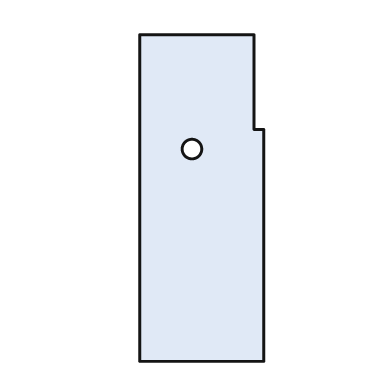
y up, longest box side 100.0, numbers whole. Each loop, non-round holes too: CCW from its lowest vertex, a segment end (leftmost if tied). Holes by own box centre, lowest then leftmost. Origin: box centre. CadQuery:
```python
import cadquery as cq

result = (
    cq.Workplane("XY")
    .moveTo(-19.0, -50.0)
    .lineTo(19.0, -50.0)
    .lineTo(19.0, 21.0)
    .lineTo(16.0, 21.0)
    .lineTo(16.0, 50.0)
    .lineTo(-19.0, 50.0)
    .close()
    .moveTo(-3.0, 15.0)
    .circle(3.0)
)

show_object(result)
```